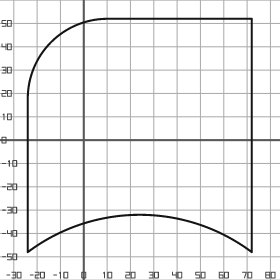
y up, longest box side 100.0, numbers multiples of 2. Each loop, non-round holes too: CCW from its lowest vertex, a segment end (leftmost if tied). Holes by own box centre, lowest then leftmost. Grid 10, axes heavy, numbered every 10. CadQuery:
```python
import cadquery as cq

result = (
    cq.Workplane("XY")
    .moveTo(-24.0, -48.0)
    .threePointArc((24.0, -32.0), (72.0, -48.0))
    .lineTo(72.0, 52.0)
    .lineTo(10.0, 52.0)
    .threePointArc((-14.0, 42.0), (-24.0, 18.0))
    .close()
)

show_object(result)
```